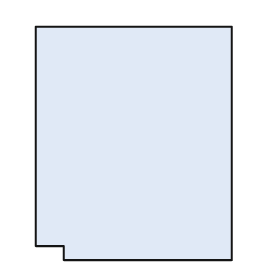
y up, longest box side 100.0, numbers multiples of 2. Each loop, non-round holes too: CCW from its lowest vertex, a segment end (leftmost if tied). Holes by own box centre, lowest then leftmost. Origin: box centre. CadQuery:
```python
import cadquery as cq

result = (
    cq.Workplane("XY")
    .moveTo(-30.0, -50.0)
    .lineTo(42.0, -50.0)
    .lineTo(42.0, 50.0)
    .lineTo(-42.0, 50.0)
    .lineTo(-42.0, -44.0)
    .lineTo(-30.0, -44.0)
    .close()
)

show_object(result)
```